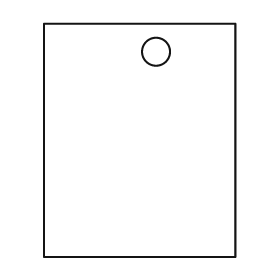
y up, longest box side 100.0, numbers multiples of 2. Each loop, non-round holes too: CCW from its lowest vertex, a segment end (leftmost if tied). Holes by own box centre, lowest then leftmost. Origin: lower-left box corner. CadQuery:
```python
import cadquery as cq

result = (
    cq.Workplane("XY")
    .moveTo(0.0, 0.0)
    .lineTo(82.0, 0.0)
    .lineTo(82.0, 100.0)
    .lineTo(0.0, 100.0)
    .close()
    .moveTo(48.0, 88.0)
    .circle(6.0)
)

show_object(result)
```